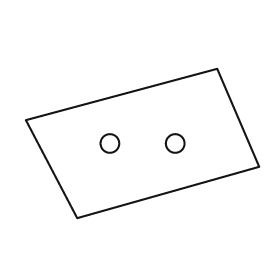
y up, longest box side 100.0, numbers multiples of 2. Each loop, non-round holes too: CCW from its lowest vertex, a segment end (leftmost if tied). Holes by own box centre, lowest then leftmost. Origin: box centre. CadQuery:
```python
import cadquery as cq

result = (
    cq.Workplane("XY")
    .moveTo(-28.0, -32.0)
    .lineTo(50.0, -10.0)
    .lineTo(32.0, 32.0)
    .lineTo(-50.0, 10.0)
    .close()
    .moveTo(-14.0, 0.0)
    .circle(4.0)
    .moveTo(14.0, 0.0)
    .circle(4.0)
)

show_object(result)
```